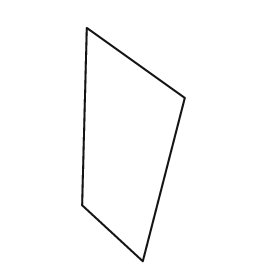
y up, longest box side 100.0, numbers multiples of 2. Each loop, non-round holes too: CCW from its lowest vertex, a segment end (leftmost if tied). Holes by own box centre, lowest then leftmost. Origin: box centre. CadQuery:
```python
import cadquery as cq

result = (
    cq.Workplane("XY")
    .moveTo(4.0, -50.0)
    .lineTo(22.0, 20.0)
    .lineTo(-20.0, 50.0)
    .lineTo(-22.0, -26.0)
    .close()
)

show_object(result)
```